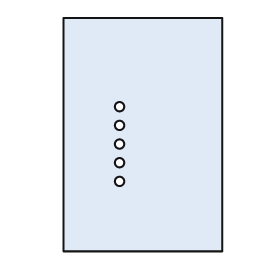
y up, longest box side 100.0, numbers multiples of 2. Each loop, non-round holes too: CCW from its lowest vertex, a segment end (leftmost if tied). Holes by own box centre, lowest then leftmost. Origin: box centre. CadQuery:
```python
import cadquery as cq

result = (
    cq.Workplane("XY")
    .moveTo(-34.0, -50.0)
    .lineTo(34.0, -50.0)
    .lineTo(34.0, 50.0)
    .lineTo(-34.0, 50.0)
    .close()
    .moveTo(-10.0, -20.0)
    .circle(2.0)
    .moveTo(-10.0, -12.0)
    .circle(2.0)
    .moveTo(-10.0, -4.0)
    .circle(2.0)
    .moveTo(-10.0, 4.0)
    .circle(2.0)
    .moveTo(-10.0, 12.0)
    .circle(2.0)
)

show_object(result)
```